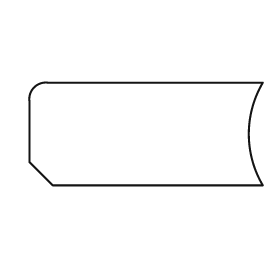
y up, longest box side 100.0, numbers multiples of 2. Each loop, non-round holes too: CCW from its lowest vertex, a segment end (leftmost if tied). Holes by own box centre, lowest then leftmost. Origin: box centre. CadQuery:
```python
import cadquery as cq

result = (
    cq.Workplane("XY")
    .moveTo(-40.0, -22.0)
    .lineTo(50.0, -22.0)
    .threePointArc((44.0, 0.0), (50.0, 22.0))
    .lineTo(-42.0, 22.0)
    .threePointArc((-48.0, 20.0), (-50.0, 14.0))
    .lineTo(-50.0, -12.0)
    .close()
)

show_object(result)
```